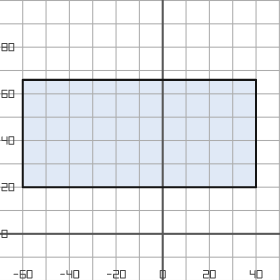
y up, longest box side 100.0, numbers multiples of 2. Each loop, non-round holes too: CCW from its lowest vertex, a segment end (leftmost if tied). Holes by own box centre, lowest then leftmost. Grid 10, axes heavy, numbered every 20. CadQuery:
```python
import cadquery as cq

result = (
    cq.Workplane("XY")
    .moveTo(-60.0, 20.0)
    .lineTo(40.0, 20.0)
    .lineTo(40.0, 66.0)
    .lineTo(-60.0, 66.0)
    .close()
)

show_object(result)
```